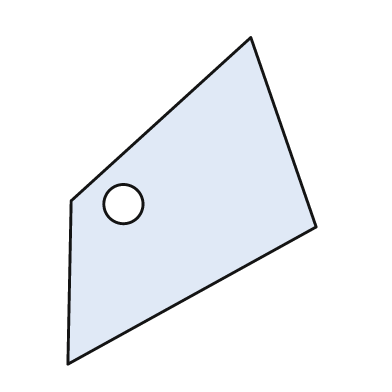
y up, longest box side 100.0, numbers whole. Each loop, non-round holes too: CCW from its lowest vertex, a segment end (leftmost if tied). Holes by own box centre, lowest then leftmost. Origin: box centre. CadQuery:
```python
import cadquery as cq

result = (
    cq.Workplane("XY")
    .moveTo(-38.0, -50.0)
    .lineTo(38.0, -8.0)
    .lineTo(18.0, 50.0)
    .lineTo(-37.0, 0.0)
    .close()
    .moveTo(-21.0, -1.0)
    .circle(6.0)
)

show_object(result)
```